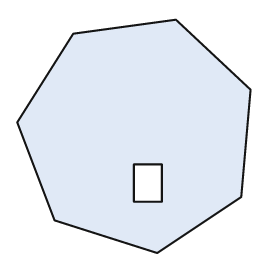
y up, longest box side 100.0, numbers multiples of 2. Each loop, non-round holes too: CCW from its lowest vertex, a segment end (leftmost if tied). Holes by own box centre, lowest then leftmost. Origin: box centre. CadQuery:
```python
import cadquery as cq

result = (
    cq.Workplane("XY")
    .moveTo(10.0, -50.0)
    .lineTo(46.0, -26.0)
    .lineTo(50.0, 20.0)
    .lineTo(18.0, 50.0)
    .lineTo(-26.0, 44.0)
    .lineTo(-50.0, 6.0)
    .lineTo(-34.0, -36.0)
    .close()
    .moveTo(0.0, -28.0)
    .lineTo(12.0, -28.0)
    .lineTo(12.0, -12.0)
    .lineTo(0.0, -12.0)
    .close()
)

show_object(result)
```